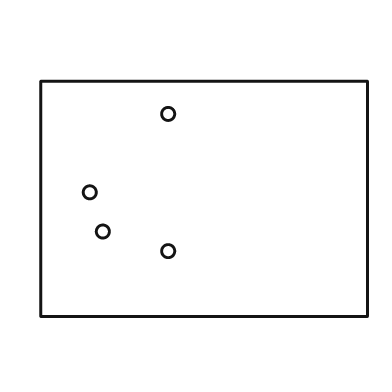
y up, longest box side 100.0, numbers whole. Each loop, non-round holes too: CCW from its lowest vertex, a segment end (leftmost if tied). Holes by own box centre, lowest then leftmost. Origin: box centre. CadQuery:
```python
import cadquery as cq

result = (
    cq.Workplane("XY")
    .moveTo(-50.0, -36.0)
    .lineTo(50.0, -36.0)
    .lineTo(50.0, 36.0)
    .lineTo(-50.0, 36.0)
    .close()
    .moveTo(-11.0, -16.0)
    .circle(2.0)
    .moveTo(-31.0, -10.0)
    .circle(2.0)
    .moveTo(-35.0, 2.0)
    .circle(2.0)
    .moveTo(-11.0, 26.0)
    .circle(2.0)
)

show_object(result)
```